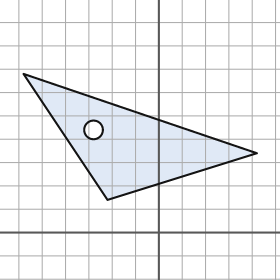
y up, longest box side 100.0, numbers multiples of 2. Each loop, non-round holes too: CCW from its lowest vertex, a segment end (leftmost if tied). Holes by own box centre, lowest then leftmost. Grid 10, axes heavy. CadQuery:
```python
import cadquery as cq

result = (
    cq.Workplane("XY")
    .moveTo(-22.0, 14.0)
    .lineTo(42.0, 34.0)
    .lineTo(-58.0, 68.0)
    .close()
    .moveTo(-28.0, 44.0)
    .circle(4.0)
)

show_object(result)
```